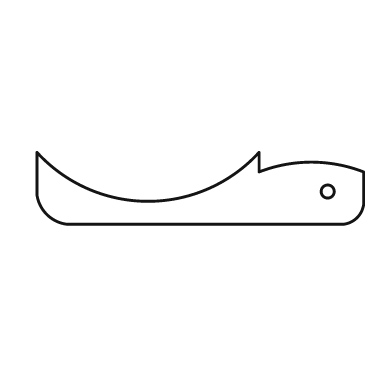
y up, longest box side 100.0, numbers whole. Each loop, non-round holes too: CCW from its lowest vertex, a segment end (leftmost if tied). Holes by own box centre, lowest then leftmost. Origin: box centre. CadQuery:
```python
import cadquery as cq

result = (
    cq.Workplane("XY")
    .moveTo(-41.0, -11.0)
    .lineTo(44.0, -11.0)
    .threePointArc((48.0, -9.0), (50.0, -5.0))
    .lineTo(50.0, 5.0)
    .threePointArc((34.0, 8.0), (18.0, 5.0))
    .lineTo(18.0, 11.0)
    .threePointArc((-16.0, -4.0), (-50.0, 11.0))
    .lineTo(-50.0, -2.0)
    .threePointArc((-47.0, -8.0), (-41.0, -11.0))
    .close()
    .moveTo(39.0, -1.0)
    .circle(2.0)
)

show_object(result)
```